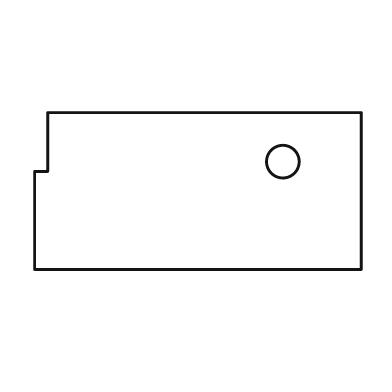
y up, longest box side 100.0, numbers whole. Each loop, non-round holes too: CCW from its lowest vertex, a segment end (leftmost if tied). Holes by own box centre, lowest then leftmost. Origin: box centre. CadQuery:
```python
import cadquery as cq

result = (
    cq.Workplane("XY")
    .moveTo(-50.0, -24.0)
    .lineTo(50.0, -24.0)
    .lineTo(50.0, 24.0)
    .lineTo(-46.0, 24.0)
    .lineTo(-46.0, 6.0)
    .lineTo(-50.0, 6.0)
    .close()
    .moveTo(26.0, 9.0)
    .circle(5.0)
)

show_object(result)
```